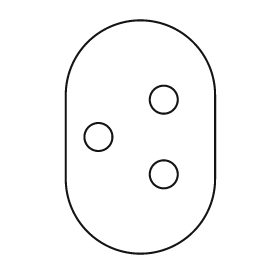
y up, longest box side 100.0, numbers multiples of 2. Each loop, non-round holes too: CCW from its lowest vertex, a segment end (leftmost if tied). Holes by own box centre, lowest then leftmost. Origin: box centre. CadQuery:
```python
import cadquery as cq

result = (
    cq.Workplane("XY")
    .moveTo(-32.0, -18.0)
    .threePointArc((0.0, -50.0), (32.0, -18.0))
    .lineTo(32.0, 18.0)
    .threePointArc((0.0, 50.0), (-32.0, 18.0))
    .close()
    .moveTo(10.0, -16.0)
    .circle(6.0)
    .moveTo(-18.0, 0.0)
    .circle(6.0)
    .moveTo(10.0, 16.0)
    .circle(6.0)
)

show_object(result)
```